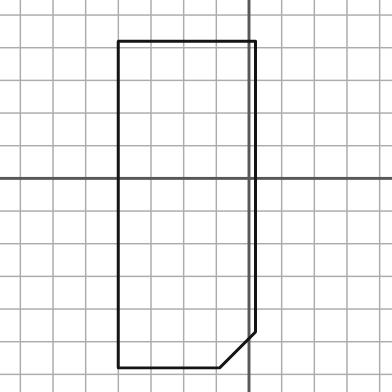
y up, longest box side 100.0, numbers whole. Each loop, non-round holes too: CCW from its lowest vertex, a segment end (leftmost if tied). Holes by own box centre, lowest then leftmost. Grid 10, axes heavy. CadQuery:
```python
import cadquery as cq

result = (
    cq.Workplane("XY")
    .moveTo(-40.0, -58.0)
    .lineTo(-9.0, -58.0)
    .lineTo(2.0, -47.0)
    .lineTo(2.0, 42.0)
    .lineTo(-40.0, 42.0)
    .close()
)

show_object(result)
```